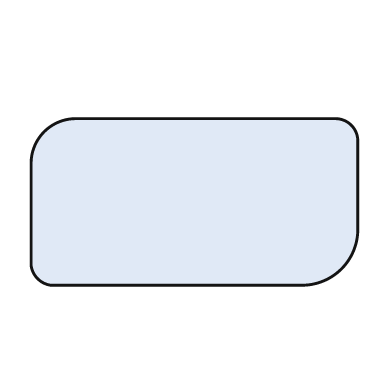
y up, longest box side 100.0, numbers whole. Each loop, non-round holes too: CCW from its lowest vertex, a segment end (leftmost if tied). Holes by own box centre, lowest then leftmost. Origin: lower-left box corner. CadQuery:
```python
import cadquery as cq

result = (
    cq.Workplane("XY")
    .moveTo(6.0, 0.0)
    .lineTo(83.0, 0.0)
    .threePointArc((95.0, 5.0), (100.0, 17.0))
    .lineTo(100.0, 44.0)
    .threePointArc((98.0, 49.0), (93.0, 51.0))
    .lineTo(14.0, 51.0)
    .threePointArc((4.0, 47.0), (0.0, 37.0))
    .lineTo(0.0, 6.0)
    .threePointArc((2.0, 2.0), (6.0, 0.0))
    .close()
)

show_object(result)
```